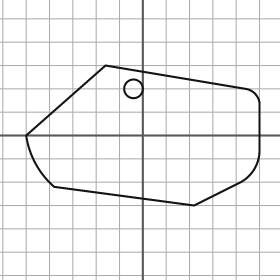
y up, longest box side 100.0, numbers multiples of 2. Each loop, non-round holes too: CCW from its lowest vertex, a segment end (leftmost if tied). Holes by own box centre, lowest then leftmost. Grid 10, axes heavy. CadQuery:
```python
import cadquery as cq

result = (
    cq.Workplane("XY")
    .moveTo(22.0, -30.0)
    .lineTo(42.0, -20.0)
    .threePointArc((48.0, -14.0), (50.0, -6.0))
    .lineTo(50.0, 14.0)
    .threePointArc((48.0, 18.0), (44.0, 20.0))
    .lineTo(-16.0, 30.0)
    .lineTo(-50.0, 0.0)
    .threePointArc((-46.0, -12.0), (-38.0, -22.0))
    .close()
    .moveTo(-4.0, 20.0)
    .circle(4.0)
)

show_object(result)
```